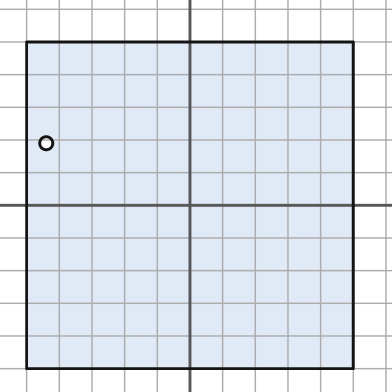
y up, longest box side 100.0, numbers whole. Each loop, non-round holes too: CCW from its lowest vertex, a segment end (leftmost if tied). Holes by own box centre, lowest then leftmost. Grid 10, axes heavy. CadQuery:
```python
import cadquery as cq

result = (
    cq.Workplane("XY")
    .moveTo(-50.0, -50.0)
    .lineTo(50.0, -50.0)
    .lineTo(50.0, 50.0)
    .lineTo(-50.0, 50.0)
    .close()
    .moveTo(-44.0, 19.0)
    .circle(2.0)
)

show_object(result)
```